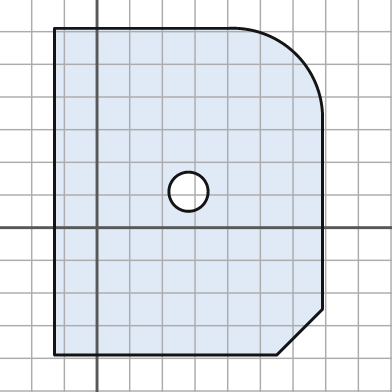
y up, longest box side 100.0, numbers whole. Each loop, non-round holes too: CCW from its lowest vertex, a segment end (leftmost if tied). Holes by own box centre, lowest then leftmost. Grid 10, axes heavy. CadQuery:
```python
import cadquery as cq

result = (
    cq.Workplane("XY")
    .moveTo(-13.0, -39.0)
    .lineTo(55.0, -39.0)
    .lineTo(69.0, -25.0)
    .lineTo(69.0, 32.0)
    .threePointArc((61.0, 53.0), (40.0, 61.0))
    .lineTo(-13.0, 61.0)
    .close()
    .moveTo(28.0, 11.0)
    .circle(6.0)
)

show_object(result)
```